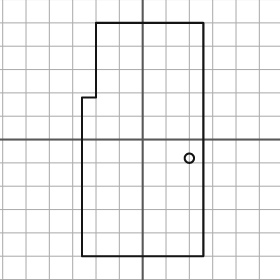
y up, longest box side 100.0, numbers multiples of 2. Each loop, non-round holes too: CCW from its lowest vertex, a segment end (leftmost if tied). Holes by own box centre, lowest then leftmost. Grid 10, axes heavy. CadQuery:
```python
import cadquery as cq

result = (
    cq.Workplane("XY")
    .moveTo(-26.0, -50.0)
    .lineTo(26.0, -50.0)
    .lineTo(26.0, 50.0)
    .lineTo(-20.0, 50.0)
    .lineTo(-20.0, 18.0)
    .lineTo(-26.0, 18.0)
    .close()
    .moveTo(20.0, -8.0)
    .circle(2.0)
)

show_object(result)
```